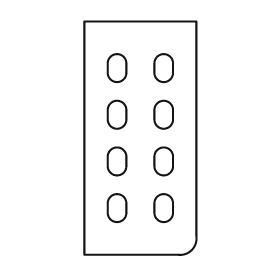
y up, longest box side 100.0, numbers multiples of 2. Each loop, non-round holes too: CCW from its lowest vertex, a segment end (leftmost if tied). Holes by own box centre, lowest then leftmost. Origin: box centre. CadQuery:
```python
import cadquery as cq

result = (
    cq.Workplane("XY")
    .moveTo(-24.0, -50.0)
    .lineTo(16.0, -50.0)
    .threePointArc((22.0, -48.0), (24.0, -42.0))
    .lineTo(24.0, 50.0)
    .lineTo(-24.0, 50.0)
    .close()
    .moveTo(-14.0, -32.0)
    .threePointArc((-10.0, -36.0), (-6.0, -32.0))
    .lineTo(-6.0, -28.0)
    .threePointArc((-10.0, -24.0), (-14.0, -28.0))
    .close()
    .moveTo(6.0, -32.0)
    .threePointArc((10.0, -36.0), (14.0, -32.0))
    .lineTo(14.0, -28.0)
    .threePointArc((10.0, -24.0), (6.0, -28.0))
    .close()
    .moveTo(-14.0, -12.0)
    .threePointArc((-10.0, -16.0), (-6.0, -12.0))
    .lineTo(-6.0, -8.0)
    .threePointArc((-10.0, -4.0), (-14.0, -8.0))
    .close()
    .moveTo(6.0, -12.0)
    .threePointArc((10.0, -16.0), (14.0, -12.0))
    .lineTo(14.0, -8.0)
    .threePointArc((10.0, -4.0), (6.0, -8.0))
    .close()
    .moveTo(-14.0, 8.0)
    .threePointArc((-10.0, 4.0), (-6.0, 8.0))
    .lineTo(-6.0, 12.0)
    .threePointArc((-10.0, 16.0), (-14.0, 12.0))
    .close()
    .moveTo(6.0, 8.0)
    .threePointArc((10.0, 4.0), (14.0, 8.0))
    .lineTo(14.0, 12.0)
    .threePointArc((10.0, 16.0), (6.0, 12.0))
    .close()
    .moveTo(-14.0, 28.0)
    .threePointArc((-10.0, 24.0), (-6.0, 28.0))
    .lineTo(-6.0, 32.0)
    .threePointArc((-10.0, 36.0), (-14.0, 32.0))
    .close()
    .moveTo(6.0, 28.0)
    .threePointArc((10.0, 24.0), (14.0, 28.0))
    .lineTo(14.0, 32.0)
    .threePointArc((10.0, 36.0), (6.0, 32.0))
    .close()
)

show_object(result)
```